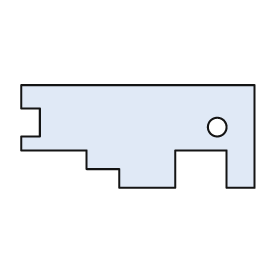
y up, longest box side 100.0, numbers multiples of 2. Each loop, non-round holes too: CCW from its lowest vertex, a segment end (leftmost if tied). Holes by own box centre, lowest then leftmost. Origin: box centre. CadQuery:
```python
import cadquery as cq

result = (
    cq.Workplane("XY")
    .moveTo(-8.0, -22.0)
    .lineTo(16.0, -22.0)
    .lineTo(16.0, -6.0)
    .lineTo(38.0, -6.0)
    .lineTo(38.0, -22.0)
    .lineTo(50.0, -22.0)
    .lineTo(50.0, 22.0)
    .lineTo(-50.0, 22.0)
    .lineTo(-50.0, 12.0)
    .lineTo(-42.0, 12.0)
    .lineTo(-42.0, 0.0)
    .lineTo(-50.0, 0.0)
    .lineTo(-50.0, -6.0)
    .lineTo(-22.0, -6.0)
    .lineTo(-22.0, -14.0)
    .lineTo(-8.0, -14.0)
    .close()
    .moveTo(34.0, 4.0)
    .circle(4.0)
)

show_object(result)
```